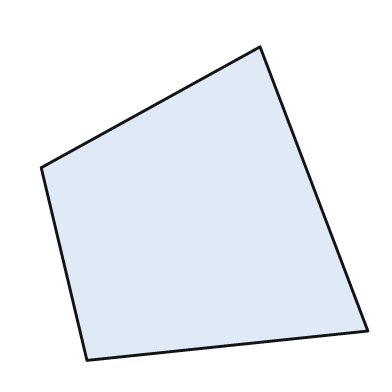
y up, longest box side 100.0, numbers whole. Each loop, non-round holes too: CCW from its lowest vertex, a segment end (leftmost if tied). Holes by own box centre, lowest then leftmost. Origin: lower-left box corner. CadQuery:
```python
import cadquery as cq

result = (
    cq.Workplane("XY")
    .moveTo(14.0, 0.0)
    .lineTo(100.0, 9.0)
    .lineTo(67.0, 96.0)
    .lineTo(0.0, 59.0)
    .close()
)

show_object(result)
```